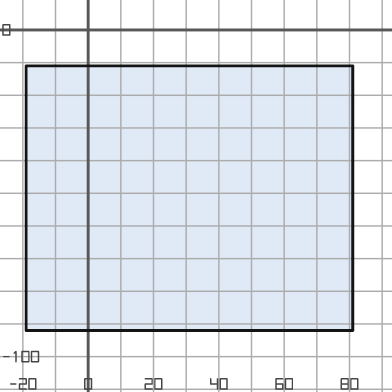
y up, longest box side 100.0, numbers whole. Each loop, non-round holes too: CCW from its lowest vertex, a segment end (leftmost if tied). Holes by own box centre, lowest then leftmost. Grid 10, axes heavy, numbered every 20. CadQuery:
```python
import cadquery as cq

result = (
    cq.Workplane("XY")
    .moveTo(-19.0, -92.0)
    .lineTo(81.0, -92.0)
    .lineTo(81.0, -11.0)
    .lineTo(-19.0, -11.0)
    .close()
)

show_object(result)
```